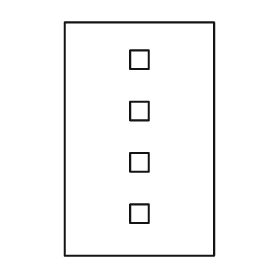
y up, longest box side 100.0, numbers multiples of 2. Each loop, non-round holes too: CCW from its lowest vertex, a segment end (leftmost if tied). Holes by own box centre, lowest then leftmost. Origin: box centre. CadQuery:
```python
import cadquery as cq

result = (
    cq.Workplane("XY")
    .moveTo(-32.0, -50.0)
    .lineTo(32.0, -50.0)
    .lineTo(32.0, 50.0)
    .lineTo(-32.0, 50.0)
    .close()
    .moveTo(-4.0, -36.0)
    .lineTo(4.0, -36.0)
    .lineTo(4.0, -28.0)
    .lineTo(-4.0, -28.0)
    .close()
    .moveTo(-4.0, -14.0)
    .lineTo(4.0, -14.0)
    .lineTo(4.0, -6.0)
    .lineTo(-4.0, -6.0)
    .close()
    .moveTo(-4.0, 8.0)
    .lineTo(4.0, 8.0)
    .lineTo(4.0, 16.0)
    .lineTo(-4.0, 16.0)
    .close()
    .moveTo(-4.0, 30.0)
    .lineTo(4.0, 30.0)
    .lineTo(4.0, 38.0)
    .lineTo(-4.0, 38.0)
    .close()
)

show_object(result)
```